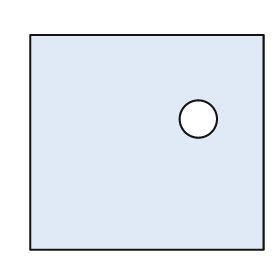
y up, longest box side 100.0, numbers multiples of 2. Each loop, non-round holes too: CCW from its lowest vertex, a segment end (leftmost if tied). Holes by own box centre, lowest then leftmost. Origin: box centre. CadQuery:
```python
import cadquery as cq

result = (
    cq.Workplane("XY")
    .moveTo(-50.0, -46.0)
    .lineTo(50.0, -46.0)
    .lineTo(50.0, 46.0)
    .lineTo(-50.0, 46.0)
    .close()
    .moveTo(22.0, 10.0)
    .circle(8.0)
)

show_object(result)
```